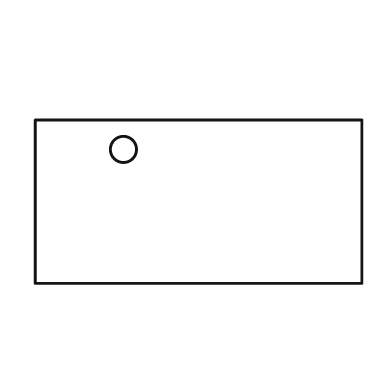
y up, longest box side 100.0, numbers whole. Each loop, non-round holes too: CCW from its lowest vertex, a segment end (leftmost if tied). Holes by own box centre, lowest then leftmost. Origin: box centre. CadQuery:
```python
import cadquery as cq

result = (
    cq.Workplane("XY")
    .moveTo(-50.0, -25.0)
    .lineTo(50.0, -25.0)
    .lineTo(50.0, 25.0)
    .lineTo(-50.0, 25.0)
    .close()
    .moveTo(-23.0, 16.0)
    .circle(4.0)
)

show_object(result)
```